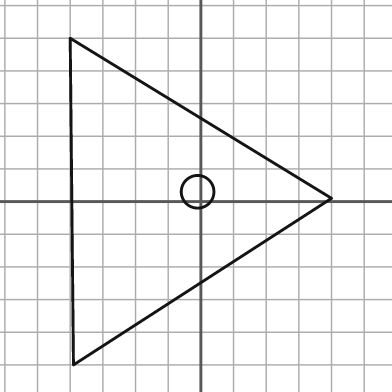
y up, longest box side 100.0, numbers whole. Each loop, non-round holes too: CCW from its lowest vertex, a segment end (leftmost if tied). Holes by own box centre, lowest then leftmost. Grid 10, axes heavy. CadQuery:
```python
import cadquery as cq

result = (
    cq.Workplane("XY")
    .moveTo(-39.0, -50.0)
    .lineTo(40.0, 1.0)
    .lineTo(-40.0, 50.0)
    .close()
    .moveTo(-1.0, 3.0)
    .circle(5.0)
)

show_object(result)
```